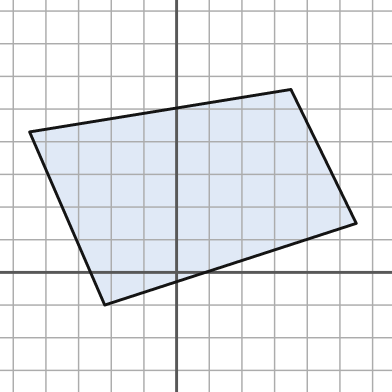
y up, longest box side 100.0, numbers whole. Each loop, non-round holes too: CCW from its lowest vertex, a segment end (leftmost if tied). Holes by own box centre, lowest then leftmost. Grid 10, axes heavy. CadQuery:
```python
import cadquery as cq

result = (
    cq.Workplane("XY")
    .moveTo(-22.0, -10.0)
    .lineTo(55.0, 15.0)
    .lineTo(35.0, 56.0)
    .lineTo(-45.0, 43.0)
    .close()
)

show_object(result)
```